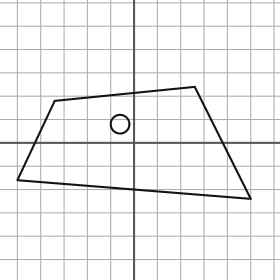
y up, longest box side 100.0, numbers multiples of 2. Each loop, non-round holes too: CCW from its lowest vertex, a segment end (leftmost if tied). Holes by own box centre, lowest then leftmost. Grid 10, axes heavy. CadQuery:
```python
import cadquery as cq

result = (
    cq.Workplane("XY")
    .moveTo(50.0, -24.0)
    .lineTo(26.0, 24.0)
    .lineTo(-34.0, 18.0)
    .lineTo(-50.0, -16.0)
    .close()
    .moveTo(-6.0, 8.0)
    .circle(4.0)
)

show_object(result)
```